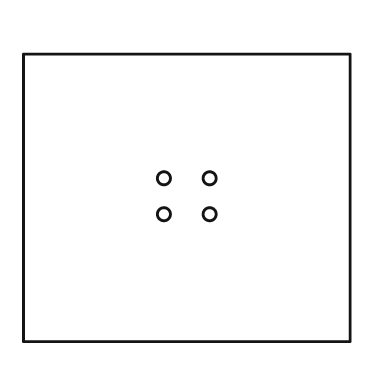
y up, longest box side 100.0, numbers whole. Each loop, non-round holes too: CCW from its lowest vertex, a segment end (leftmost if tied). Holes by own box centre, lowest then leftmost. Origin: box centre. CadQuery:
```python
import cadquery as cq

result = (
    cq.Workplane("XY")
    .moveTo(-50.0, -44.0)
    .lineTo(50.0, -44.0)
    .lineTo(50.0, 44.0)
    .lineTo(-50.0, 44.0)
    .close()
    .moveTo(-7.0, -5.0)
    .circle(2.0)
    .moveTo(7.0, -5.0)
    .circle(2.0)
    .moveTo(-7.0, 6.0)
    .circle(2.0)
    .moveTo(7.0, 6.0)
    .circle(2.0)
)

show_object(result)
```